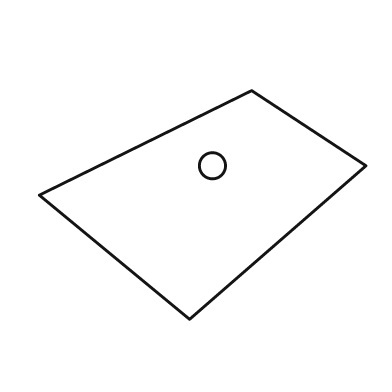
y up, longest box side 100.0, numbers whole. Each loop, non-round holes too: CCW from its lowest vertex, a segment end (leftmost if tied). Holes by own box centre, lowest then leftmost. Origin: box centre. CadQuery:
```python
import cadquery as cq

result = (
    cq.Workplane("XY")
    .moveTo(-4.0, -35.0)
    .lineTo(50.0, 12.0)
    .lineTo(15.0, 35.0)
    .lineTo(-50.0, 3.0)
    .close()
    .moveTo(3.0, 12.0)
    .circle(4.0)
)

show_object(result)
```